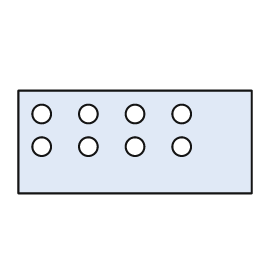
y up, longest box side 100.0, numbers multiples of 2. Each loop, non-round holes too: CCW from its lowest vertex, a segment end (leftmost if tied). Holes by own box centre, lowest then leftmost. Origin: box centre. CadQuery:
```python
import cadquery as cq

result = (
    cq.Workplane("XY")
    .moveTo(-50.0, -22.0)
    .lineTo(50.0, -22.0)
    .lineTo(50.0, 22.0)
    .lineTo(-50.0, 22.0)
    .close()
    .moveTo(-40.0, -2.0)
    .circle(4.0)
    .moveTo(-20.0, -2.0)
    .circle(4.0)
    .moveTo(0.0, -2.0)
    .circle(4.0)
    .moveTo(20.0, -2.0)
    .circle(4.0)
    .moveTo(-40.0, 12.0)
    .circle(4.0)
    .moveTo(-20.0, 12.0)
    .circle(4.0)
    .moveTo(0.0, 12.0)
    .circle(4.0)
    .moveTo(20.0, 12.0)
    .circle(4.0)
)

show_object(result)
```